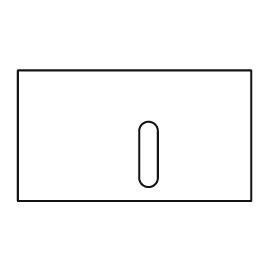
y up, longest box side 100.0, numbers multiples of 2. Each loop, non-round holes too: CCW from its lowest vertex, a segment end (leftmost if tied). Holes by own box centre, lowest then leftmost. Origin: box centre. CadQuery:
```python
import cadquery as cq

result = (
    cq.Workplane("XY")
    .moveTo(-50.0, -28.0)
    .lineTo(50.0, -28.0)
    .lineTo(50.0, 28.0)
    .lineTo(-50.0, 28.0)
    .close()
    .moveTo(2.0, -18.0)
    .threePointArc((6.0, -22.0), (10.0, -18.0))
    .lineTo(10.0, 2.0)
    .threePointArc((6.0, 6.0), (2.0, 2.0))
    .close()
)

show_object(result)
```